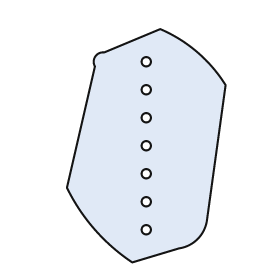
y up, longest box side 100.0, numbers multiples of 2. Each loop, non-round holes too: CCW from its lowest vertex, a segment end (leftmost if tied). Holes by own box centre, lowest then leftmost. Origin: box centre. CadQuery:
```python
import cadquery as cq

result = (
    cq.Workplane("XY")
    .moveTo(-6.0, -50.0)
    .lineTo(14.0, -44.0)
    .threePointArc((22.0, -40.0), (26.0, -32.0))
    .lineTo(34.0, 26.0)
    .threePointArc((22.0, 40.0), (6.0, 50.0))
    .lineTo(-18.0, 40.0)
    .threePointArc((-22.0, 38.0), (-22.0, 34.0))
    .lineTo(-34.0, -18.0)
    .threePointArc((-22.0, -36.0), (-6.0, -50.0))
    .close()
    .moveTo(0.0, -36.0)
    .circle(2.0)
    .moveTo(0.0, -24.0)
    .circle(2.0)
    .moveTo(0.0, -12.0)
    .circle(2.0)
    .moveTo(0.0, 0.0)
    .circle(2.0)
    .moveTo(0.0, 12.0)
    .circle(2.0)
    .moveTo(0.0, 24.0)
    .circle(2.0)
    .moveTo(0.0, 36.0)
    .circle(2.0)
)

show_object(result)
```